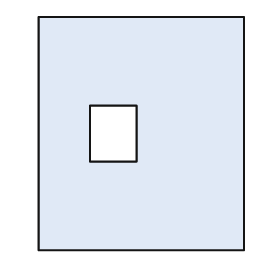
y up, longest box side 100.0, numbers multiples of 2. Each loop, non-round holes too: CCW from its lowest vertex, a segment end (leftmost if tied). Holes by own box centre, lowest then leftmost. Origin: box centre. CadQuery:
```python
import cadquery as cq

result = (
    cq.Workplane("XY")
    .moveTo(-44.0, -50.0)
    .lineTo(44.0, -50.0)
    .lineTo(44.0, 50.0)
    .lineTo(-44.0, 50.0)
    .close()
    .moveTo(-22.0, -12.0)
    .lineTo(-2.0, -12.0)
    .lineTo(-2.0, 12.0)
    .lineTo(-22.0, 12.0)
    .close()
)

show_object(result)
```